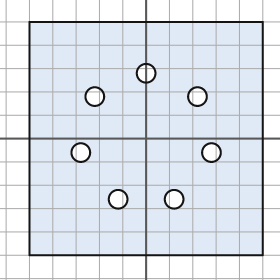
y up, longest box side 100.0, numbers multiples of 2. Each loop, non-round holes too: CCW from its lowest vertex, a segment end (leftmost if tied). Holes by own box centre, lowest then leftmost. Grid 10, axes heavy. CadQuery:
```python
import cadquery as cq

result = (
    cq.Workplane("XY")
    .moveTo(-50.0, -50.0)
    .lineTo(50.0, -50.0)
    .lineTo(50.0, 50.0)
    .lineTo(-50.0, 50.0)
    .close()
    .moveTo(-12.0, -26.0)
    .circle(4.0)
    .moveTo(12.0, -26.0)
    .circle(4.0)
    .moveTo(-28.0, -6.0)
    .circle(4.0)
    .moveTo(28.0, -6.0)
    .circle(4.0)
    .moveTo(-22.0, 18.0)
    .circle(4.0)
    .moveTo(22.0, 18.0)
    .circle(4.0)
    .moveTo(0.0, 28.0)
    .circle(4.0)
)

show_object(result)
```